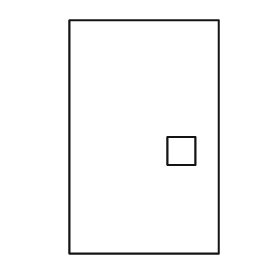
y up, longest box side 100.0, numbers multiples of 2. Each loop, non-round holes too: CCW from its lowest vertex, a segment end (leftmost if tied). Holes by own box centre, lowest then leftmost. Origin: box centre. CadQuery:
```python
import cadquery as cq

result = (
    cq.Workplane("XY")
    .moveTo(-32.0, -50.0)
    .lineTo(32.0, -50.0)
    .lineTo(32.0, 50.0)
    .lineTo(-32.0, 50.0)
    .close()
    .moveTo(10.0, -12.0)
    .lineTo(22.0, -12.0)
    .lineTo(22.0, 0.0)
    .lineTo(10.0, 0.0)
    .close()
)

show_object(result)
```